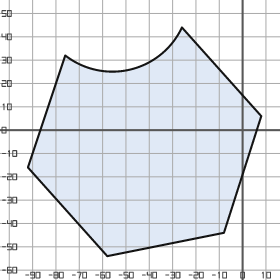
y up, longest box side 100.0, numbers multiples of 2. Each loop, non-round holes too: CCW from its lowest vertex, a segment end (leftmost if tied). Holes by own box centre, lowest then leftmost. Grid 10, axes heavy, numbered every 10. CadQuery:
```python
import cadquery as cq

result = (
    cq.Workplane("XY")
    .moveTo(-58.0, -54.0)
    .lineTo(-8.0, -44.0)
    .lineTo(8.0, 6.0)
    .lineTo(-26.0, 44.0)
    .threePointArc((-48.0, 26.0), (-76.0, 32.0))
    .lineTo(-92.0, -16.0)
    .close()
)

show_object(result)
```